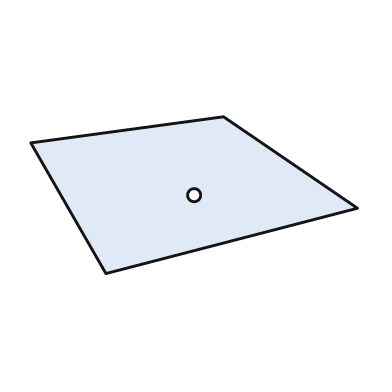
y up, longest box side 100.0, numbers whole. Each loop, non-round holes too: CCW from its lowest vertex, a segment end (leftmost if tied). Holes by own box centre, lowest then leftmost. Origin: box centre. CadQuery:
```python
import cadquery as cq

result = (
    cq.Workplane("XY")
    .moveTo(-27.0, -24.0)
    .lineTo(50.0, -4.0)
    .lineTo(9.0, 24.0)
    .lineTo(-50.0, 16.0)
    .close()
    .moveTo(0.0, 0.0)
    .circle(2.0)
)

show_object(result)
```